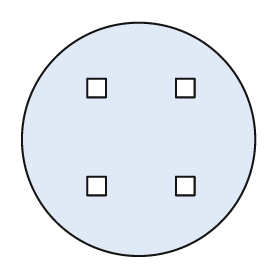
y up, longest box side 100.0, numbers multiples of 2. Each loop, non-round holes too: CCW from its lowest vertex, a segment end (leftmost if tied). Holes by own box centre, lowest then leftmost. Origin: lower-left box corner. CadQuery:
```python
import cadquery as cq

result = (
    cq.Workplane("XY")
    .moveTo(50.0, 50.0)
    .circle(50.0)
    .moveTo(28.0, 26.0)
    .lineTo(36.0, 26.0)
    .lineTo(36.0, 34.0)
    .lineTo(28.0, 34.0)
    .close()
    .moveTo(66.0, 26.0)
    .lineTo(74.0, 26.0)
    .lineTo(74.0, 34.0)
    .lineTo(66.0, 34.0)
    .close()
    .moveTo(28.0, 68.0)
    .lineTo(36.0, 68.0)
    .lineTo(36.0, 76.0)
    .lineTo(28.0, 76.0)
    .close()
    .moveTo(66.0, 68.0)
    .lineTo(74.0, 68.0)
    .lineTo(74.0, 76.0)
    .lineTo(66.0, 76.0)
    .close()
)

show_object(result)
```